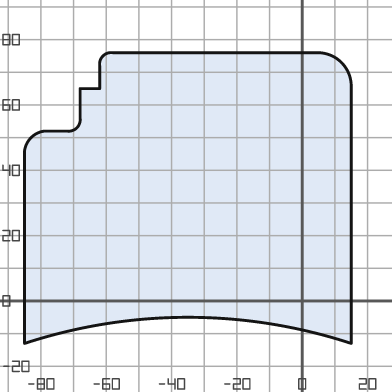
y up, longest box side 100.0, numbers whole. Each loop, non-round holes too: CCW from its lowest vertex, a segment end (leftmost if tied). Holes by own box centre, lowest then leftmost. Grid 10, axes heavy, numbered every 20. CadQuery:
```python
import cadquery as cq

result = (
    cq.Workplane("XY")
    .moveTo(-85.0, -13.0)
    .threePointArc((-35.0, -5.0), (15.0, -13.0))
    .lineTo(15.0, 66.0)
    .threePointArc((12.0, 73.0), (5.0, 76.0))
    .lineTo(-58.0, 76.0)
    .threePointArc((-61.0, 75.0), (-62.0, 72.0))
    .lineTo(-62.0, 65.0)
    .lineTo(-68.0, 65.0)
    .lineTo(-68.0, 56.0)
    .threePointArc((-69.0, 53.0), (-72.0, 52.0))
    .lineTo(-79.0, 52.0)
    .threePointArc((-83.0, 50.0), (-85.0, 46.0))
    .close()
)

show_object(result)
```